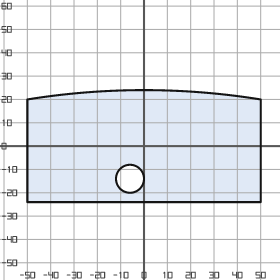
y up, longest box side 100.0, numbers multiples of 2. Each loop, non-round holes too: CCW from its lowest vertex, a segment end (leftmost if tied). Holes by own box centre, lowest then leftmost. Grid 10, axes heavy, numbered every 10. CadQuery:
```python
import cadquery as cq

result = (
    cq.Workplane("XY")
    .moveTo(-50.0, -24.0)
    .lineTo(50.0, -24.0)
    .lineTo(50.0, 20.0)
    .threePointArc((0.0, 24.0), (-50.0, 20.0))
    .close()
    .moveTo(-6.0, -14.0)
    .circle(6.0)
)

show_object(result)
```